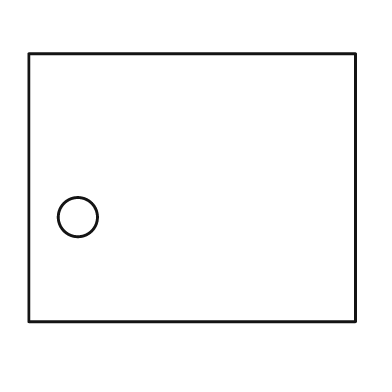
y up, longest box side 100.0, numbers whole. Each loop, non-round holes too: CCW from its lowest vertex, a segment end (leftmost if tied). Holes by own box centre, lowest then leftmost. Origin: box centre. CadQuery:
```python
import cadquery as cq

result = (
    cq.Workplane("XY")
    .moveTo(-50.0, -41.0)
    .lineTo(50.0, -41.0)
    .lineTo(50.0, 41.0)
    .lineTo(-50.0, 41.0)
    .close()
    .moveTo(-35.0, -9.0)
    .circle(6.0)
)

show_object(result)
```